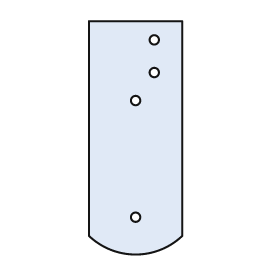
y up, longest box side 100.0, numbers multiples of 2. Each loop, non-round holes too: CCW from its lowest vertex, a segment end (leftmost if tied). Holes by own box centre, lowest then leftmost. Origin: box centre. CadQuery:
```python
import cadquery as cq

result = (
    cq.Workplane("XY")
    .moveTo(-20.0, -42.0)
    .threePointArc((0.0, -50.0), (20.0, -42.0))
    .lineTo(20.0, 50.0)
    .lineTo(-20.0, 50.0)
    .close()
    .moveTo(0.0, -34.0)
    .circle(2.0)
    .moveTo(0.0, 16.0)
    .circle(2.0)
    .moveTo(8.0, 28.0)
    .circle(2.0)
    .moveTo(8.0, 42.0)
    .circle(2.0)
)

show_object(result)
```